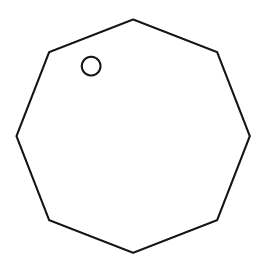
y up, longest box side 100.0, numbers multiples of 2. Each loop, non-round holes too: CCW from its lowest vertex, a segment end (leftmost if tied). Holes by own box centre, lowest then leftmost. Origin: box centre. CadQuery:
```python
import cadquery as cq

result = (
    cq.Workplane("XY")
    .moveTo(0.0, -50.0)
    .lineTo(36.0, -36.0)
    .lineTo(50.0, 0.0)
    .lineTo(36.0, 36.0)
    .lineTo(0.0, 50.0)
    .lineTo(-36.0, 36.0)
    .lineTo(-50.0, 0.0)
    .lineTo(-36.0, -36.0)
    .close()
    .moveTo(-18.0, 30.0)
    .circle(4.0)
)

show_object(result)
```